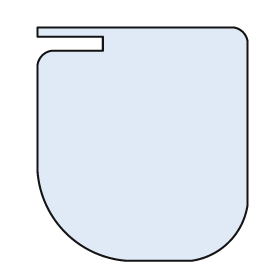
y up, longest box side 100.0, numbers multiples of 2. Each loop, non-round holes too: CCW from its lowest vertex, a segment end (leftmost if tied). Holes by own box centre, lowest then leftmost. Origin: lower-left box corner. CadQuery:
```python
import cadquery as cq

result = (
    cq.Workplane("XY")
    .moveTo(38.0, 0.0)
    .lineTo(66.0, 0.0)
    .threePointArc((82.0, 8.0), (90.0, 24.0))
    .lineTo(90.0, 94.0)
    .threePointArc((88.0, 98.0), (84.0, 100.0))
    .lineTo(0.0, 100.0)
    .lineTo(0.0, 96.0)
    .lineTo(28.0, 96.0)
    .lineTo(28.0, 90.0)
    .lineTo(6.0, 90.0)
    .threePointArc((2.0, 88.0), (0.0, 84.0))
    .lineTo(0.0, 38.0)
    .threePointArc((12.0, 12.0), (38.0, 0.0))
    .close()
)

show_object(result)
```